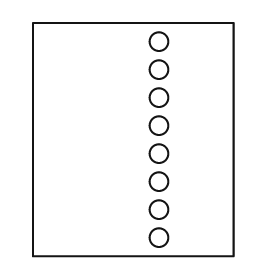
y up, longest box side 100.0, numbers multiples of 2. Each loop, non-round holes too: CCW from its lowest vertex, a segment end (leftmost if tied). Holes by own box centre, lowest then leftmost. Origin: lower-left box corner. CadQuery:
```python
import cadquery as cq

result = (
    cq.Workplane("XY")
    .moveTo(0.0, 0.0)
    .lineTo(86.0, 0.0)
    .lineTo(86.0, 100.0)
    .lineTo(0.0, 100.0)
    .close()
    .moveTo(54.0, 8.0)
    .circle(4.0)
    .moveTo(54.0, 20.0)
    .circle(4.0)
    .moveTo(54.0, 32.0)
    .circle(4.0)
    .moveTo(54.0, 44.0)
    .circle(4.0)
    .moveTo(54.0, 56.0)
    .circle(4.0)
    .moveTo(54.0, 68.0)
    .circle(4.0)
    .moveTo(54.0, 80.0)
    .circle(4.0)
    .moveTo(54.0, 92.0)
    .circle(4.0)
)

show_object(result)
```